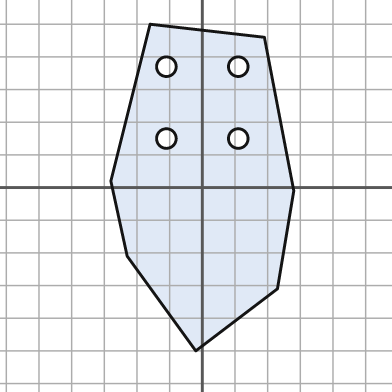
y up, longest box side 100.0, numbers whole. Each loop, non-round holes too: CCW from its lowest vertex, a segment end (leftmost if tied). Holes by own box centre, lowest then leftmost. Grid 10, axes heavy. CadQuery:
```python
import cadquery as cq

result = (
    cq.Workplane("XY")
    .moveTo(-2.0, -50.0)
    .lineTo(23.0, -31.0)
    .lineTo(28.0, -1.0)
    .lineTo(19.0, 46.0)
    .lineTo(-16.0, 50.0)
    .lineTo(-28.0, 2.0)
    .lineTo(-23.0, -21.0)
    .close()
    .moveTo(-11.0, 15.0)
    .circle(3.0)
    .moveTo(11.0, 15.0)
    .circle(3.0)
    .moveTo(-11.0, 37.0)
    .circle(3.0)
    .moveTo(11.0, 37.0)
    .circle(3.0)
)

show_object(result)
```